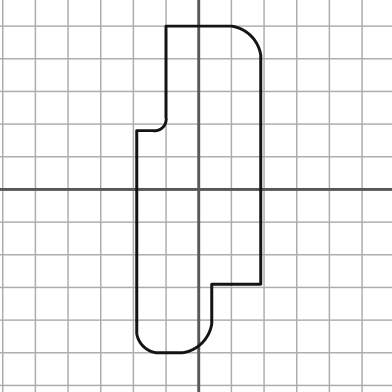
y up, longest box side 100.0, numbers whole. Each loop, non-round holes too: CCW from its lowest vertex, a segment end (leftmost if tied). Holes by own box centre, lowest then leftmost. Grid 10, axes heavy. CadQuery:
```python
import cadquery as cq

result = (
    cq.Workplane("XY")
    .moveTo(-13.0, -50.0)
    .lineTo(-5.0, -50.0)
    .threePointArc((1.0, -47.0), (4.0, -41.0))
    .lineTo(4.0, -29.0)
    .lineTo(19.0, -29.0)
    .lineTo(19.0, 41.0)
    .threePointArc((16.0, 47.0), (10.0, 50.0))
    .lineTo(-10.0, 50.0)
    .lineTo(-10.0, 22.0)
    .threePointArc((-11.0, 19.0), (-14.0, 18.0))
    .lineTo(-19.0, 18.0)
    .lineTo(-19.0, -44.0)
    .threePointArc((-17.0, -48.0), (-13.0, -50.0))
    .close()
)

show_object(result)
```